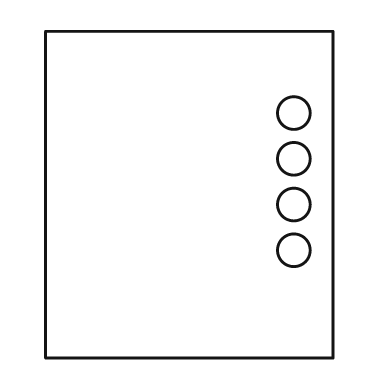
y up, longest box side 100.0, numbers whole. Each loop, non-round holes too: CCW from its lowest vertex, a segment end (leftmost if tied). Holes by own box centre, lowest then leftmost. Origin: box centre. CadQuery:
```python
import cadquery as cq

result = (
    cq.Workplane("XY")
    .moveTo(-44.0, -50.0)
    .lineTo(44.0, -50.0)
    .lineTo(44.0, 50.0)
    .lineTo(-44.0, 50.0)
    .close()
    .moveTo(32.0, -17.0)
    .circle(5.0)
    .moveTo(32.0, -3.0)
    .circle(5.0)
    .moveTo(32.0, 11.0)
    .circle(5.0)
    .moveTo(32.0, 25.0)
    .circle(5.0)
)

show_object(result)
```